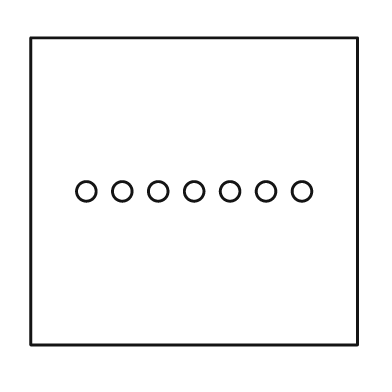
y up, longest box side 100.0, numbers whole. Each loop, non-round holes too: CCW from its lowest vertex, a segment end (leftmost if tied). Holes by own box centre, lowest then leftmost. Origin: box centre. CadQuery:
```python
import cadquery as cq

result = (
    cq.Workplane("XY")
    .moveTo(-50.0, -47.0)
    .lineTo(50.0, -47.0)
    .lineTo(50.0, 47.0)
    .lineTo(-50.0, 47.0)
    .close()
    .moveTo(-33.0, 0.0)
    .circle(3.0)
    .moveTo(-22.0, 0.0)
    .circle(3.0)
    .moveTo(-11.0, 0.0)
    .circle(3.0)
    .moveTo(0.0, 0.0)
    .circle(3.0)
    .moveTo(11.0, 0.0)
    .circle(3.0)
    .moveTo(22.0, 0.0)
    .circle(3.0)
    .moveTo(33.0, 0.0)
    .circle(3.0)
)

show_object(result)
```